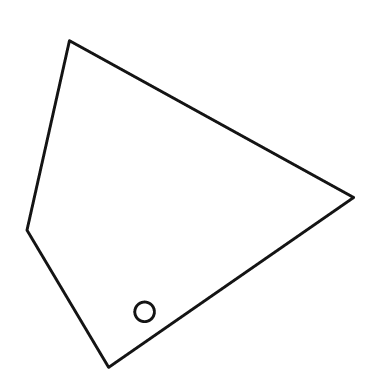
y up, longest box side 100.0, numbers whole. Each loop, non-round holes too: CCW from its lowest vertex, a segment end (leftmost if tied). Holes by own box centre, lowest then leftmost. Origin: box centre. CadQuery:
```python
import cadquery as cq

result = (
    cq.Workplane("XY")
    .moveTo(-25.0, -50.0)
    .lineTo(50.0, 2.0)
    .lineTo(-37.0, 50.0)
    .lineTo(-50.0, -8.0)
    .close()
    .moveTo(-14.0, -33.0)
    .circle(3.0)
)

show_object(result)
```